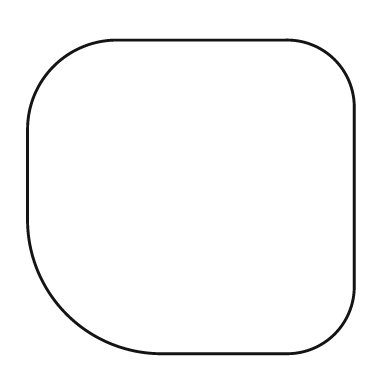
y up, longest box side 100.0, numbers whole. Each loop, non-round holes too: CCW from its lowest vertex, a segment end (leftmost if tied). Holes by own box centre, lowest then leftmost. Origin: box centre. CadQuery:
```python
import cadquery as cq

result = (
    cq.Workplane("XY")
    .moveTo(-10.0, -48.0)
    .lineTo(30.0, -48.0)
    .threePointArc((44.0, -42.0), (50.0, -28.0))
    .lineTo(50.0, 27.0)
    .threePointArc((44.0, 42.0), (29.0, 48.0))
    .lineTo(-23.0, 48.0)
    .threePointArc((-42.0, 40.0), (-50.0, 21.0))
    .lineTo(-50.0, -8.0)
    .threePointArc((-38.0, -36.0), (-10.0, -48.0))
    .close()
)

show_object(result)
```